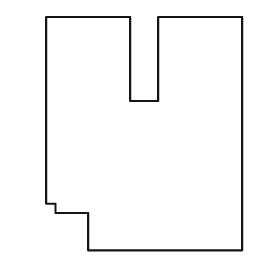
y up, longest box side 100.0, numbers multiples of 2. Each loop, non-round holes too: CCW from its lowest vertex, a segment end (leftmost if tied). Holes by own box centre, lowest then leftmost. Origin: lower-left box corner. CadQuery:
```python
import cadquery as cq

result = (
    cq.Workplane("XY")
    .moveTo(18.0, 0.0)
    .lineTo(84.0, 0.0)
    .lineTo(84.0, 100.0)
    .lineTo(48.0, 100.0)
    .lineTo(48.0, 64.0)
    .lineTo(36.0, 64.0)
    .lineTo(36.0, 100.0)
    .lineTo(0.0, 100.0)
    .lineTo(0.0, 20.0)
    .lineTo(4.0, 20.0)
    .lineTo(4.0, 16.0)
    .lineTo(18.0, 16.0)
    .close()
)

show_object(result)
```